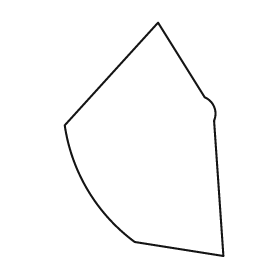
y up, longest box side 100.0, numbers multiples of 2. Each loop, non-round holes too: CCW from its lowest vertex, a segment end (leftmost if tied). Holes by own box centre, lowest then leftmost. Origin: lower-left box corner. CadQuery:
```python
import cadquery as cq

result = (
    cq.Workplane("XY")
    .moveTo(68.0, 0.0)
    .lineTo(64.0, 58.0)
    .threePointArc((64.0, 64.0), (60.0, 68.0))
    .lineTo(40.0, 100.0)
    .lineTo(0.0, 56.0)
    .threePointArc((10.0, 28.0), (30.0, 6.0))
    .close()
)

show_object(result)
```